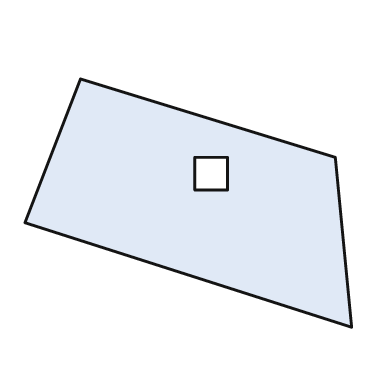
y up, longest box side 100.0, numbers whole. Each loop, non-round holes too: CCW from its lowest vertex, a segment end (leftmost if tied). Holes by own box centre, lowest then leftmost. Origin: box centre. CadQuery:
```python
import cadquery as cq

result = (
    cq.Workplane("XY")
    .moveTo(50.0, -38.0)
    .lineTo(45.0, 14.0)
    .lineTo(-33.0, 38.0)
    .lineTo(-50.0, -6.0)
    .close()
    .moveTo(2.0, 4.0)
    .lineTo(12.0, 4.0)
    .lineTo(12.0, 14.0)
    .lineTo(2.0, 14.0)
    .close()
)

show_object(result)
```